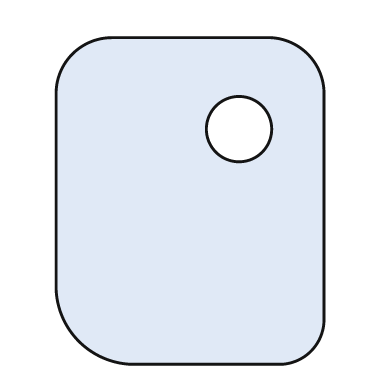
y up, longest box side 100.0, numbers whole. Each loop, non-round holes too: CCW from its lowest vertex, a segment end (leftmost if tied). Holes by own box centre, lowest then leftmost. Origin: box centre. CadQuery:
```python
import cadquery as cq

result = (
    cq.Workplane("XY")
    .moveTo(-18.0, -50.0)
    .lineTo(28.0, -50.0)
    .threePointArc((37.0, -46.0), (41.0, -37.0))
    .lineTo(41.0, 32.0)
    .threePointArc((36.0, 45.0), (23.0, 50.0))
    .lineTo(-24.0, 50.0)
    .threePointArc((-36.0, 45.0), (-41.0, 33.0))
    .lineTo(-41.0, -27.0)
    .threePointArc((-34.0, -43.0), (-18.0, -50.0))
    .close()
    .moveTo(15.0, 22.0)
    .circle(10.0)
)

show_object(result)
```